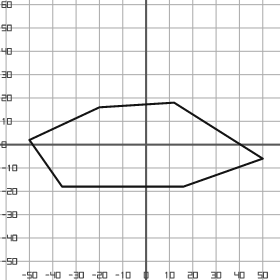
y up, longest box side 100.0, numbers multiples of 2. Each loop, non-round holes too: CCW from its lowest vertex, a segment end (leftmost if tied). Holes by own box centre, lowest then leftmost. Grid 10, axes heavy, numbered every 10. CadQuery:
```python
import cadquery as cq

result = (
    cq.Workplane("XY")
    .moveTo(-36.0, -18.0)
    .lineTo(16.0, -18.0)
    .lineTo(50.0, -6.0)
    .lineTo(12.0, 18.0)
    .lineTo(-20.0, 16.0)
    .lineTo(-50.0, 2.0)
    .close()
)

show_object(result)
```